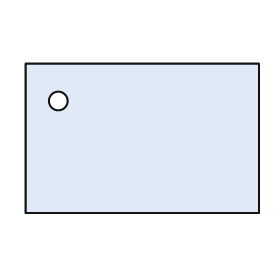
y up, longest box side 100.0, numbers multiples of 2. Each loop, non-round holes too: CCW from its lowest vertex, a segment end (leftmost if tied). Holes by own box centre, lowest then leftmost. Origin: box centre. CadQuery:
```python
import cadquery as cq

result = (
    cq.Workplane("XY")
    .moveTo(-50.0, -32.0)
    .lineTo(50.0, -32.0)
    .lineTo(50.0, 32.0)
    .lineTo(-50.0, 32.0)
    .close()
    .moveTo(-36.0, 16.0)
    .circle(4.0)
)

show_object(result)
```